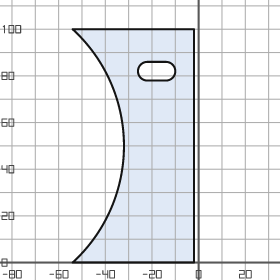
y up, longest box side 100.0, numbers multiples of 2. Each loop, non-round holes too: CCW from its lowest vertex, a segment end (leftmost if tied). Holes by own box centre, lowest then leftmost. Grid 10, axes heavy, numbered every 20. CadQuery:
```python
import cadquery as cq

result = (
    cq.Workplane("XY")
    .moveTo(-54.0, 0.0)
    .lineTo(-2.0, 0.0)
    .lineTo(-2.0, 100.0)
    .lineTo(-54.0, 100.0)
    .threePointArc((-32.0, 50.0), (-54.0, 0.0))
    .close()
    .moveTo(-22.0, 78.0)
    .lineTo(-14.0, 78.0)
    .threePointArc((-10.0, 82.0), (-14.0, 86.0))
    .lineTo(-22.0, 86.0)
    .threePointArc((-26.0, 82.0), (-22.0, 78.0))
    .close()
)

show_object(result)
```